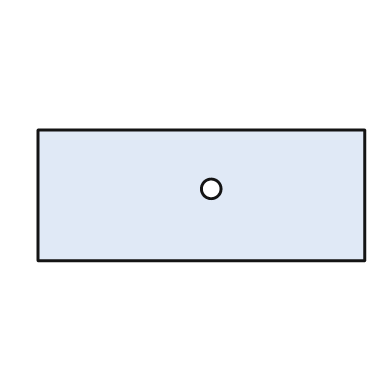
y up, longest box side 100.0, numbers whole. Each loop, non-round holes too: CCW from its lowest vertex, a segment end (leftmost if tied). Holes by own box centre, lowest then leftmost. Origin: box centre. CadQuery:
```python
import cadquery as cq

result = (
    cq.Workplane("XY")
    .moveTo(-50.0, -20.0)
    .lineTo(50.0, -20.0)
    .lineTo(50.0, 20.0)
    .lineTo(-50.0, 20.0)
    .close()
    .moveTo(3.0, 2.0)
    .circle(3.0)
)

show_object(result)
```